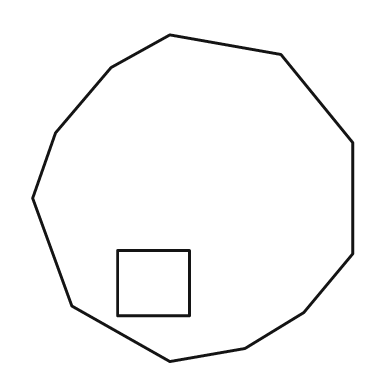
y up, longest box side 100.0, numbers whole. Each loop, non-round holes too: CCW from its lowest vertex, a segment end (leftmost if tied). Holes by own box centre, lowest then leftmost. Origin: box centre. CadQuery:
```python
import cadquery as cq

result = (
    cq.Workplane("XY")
    .moveTo(-7.0, -50.0)
    .lineTo(16.0, -46.0)
    .lineTo(34.0, -35.0)
    .lineTo(49.0, -17.0)
    .lineTo(49.0, 17.0)
    .lineTo(27.0, 44.0)
    .lineTo(-7.0, 50.0)
    .lineTo(-25.0, 40.0)
    .lineTo(-42.0, 20.0)
    .lineTo(-49.0, 0.0)
    .lineTo(-37.0, -33.0)
    .close()
    .moveTo(-23.0, -36.0)
    .lineTo(-1.0, -36.0)
    .lineTo(-1.0, -16.0)
    .lineTo(-23.0, -16.0)
    .close()
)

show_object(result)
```